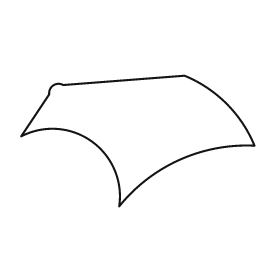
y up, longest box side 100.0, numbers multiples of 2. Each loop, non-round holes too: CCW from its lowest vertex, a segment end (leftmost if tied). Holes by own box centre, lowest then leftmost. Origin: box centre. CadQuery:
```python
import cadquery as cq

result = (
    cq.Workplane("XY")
    .moveTo(-8.0, -28.0)
    .threePointArc((18.0, -8.0), (50.0, -2.0))
    .threePointArc((38.0, 16.0), (20.0, 28.0))
    .lineTo(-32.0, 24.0)
    .threePointArc((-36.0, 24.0), (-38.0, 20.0))
    .lineTo(-50.0, 2.0)
    .threePointArc((-20.0, 0.0), (-8.0, -28.0))
    .close()
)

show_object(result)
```